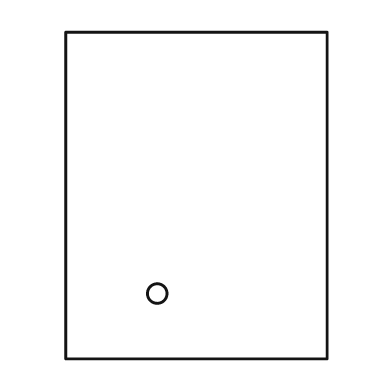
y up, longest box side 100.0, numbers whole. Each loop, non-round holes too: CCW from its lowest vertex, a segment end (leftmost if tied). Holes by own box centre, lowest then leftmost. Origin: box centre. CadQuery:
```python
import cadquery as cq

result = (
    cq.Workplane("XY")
    .moveTo(-40.0, -50.0)
    .lineTo(40.0, -50.0)
    .lineTo(40.0, 50.0)
    .lineTo(-40.0, 50.0)
    .close()
    .moveTo(-12.0, -30.0)
    .circle(3.0)
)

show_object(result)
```